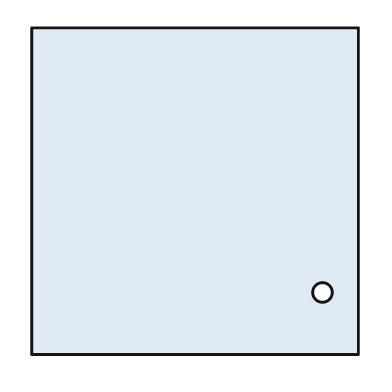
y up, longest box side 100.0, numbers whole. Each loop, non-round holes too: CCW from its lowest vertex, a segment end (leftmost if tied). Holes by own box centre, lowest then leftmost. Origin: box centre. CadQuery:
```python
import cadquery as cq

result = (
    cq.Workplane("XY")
    .moveTo(-50.0, -50.0)
    .lineTo(50.0, -50.0)
    .lineTo(50.0, 50.0)
    .lineTo(-50.0, 50.0)
    .close()
    .moveTo(39.0, -31.0)
    .circle(3.0)
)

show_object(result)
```